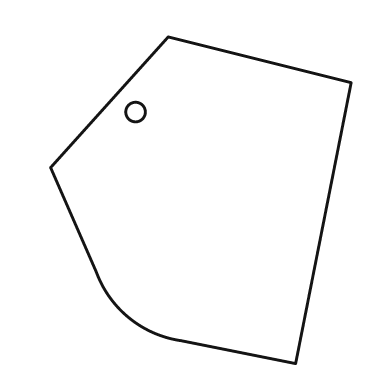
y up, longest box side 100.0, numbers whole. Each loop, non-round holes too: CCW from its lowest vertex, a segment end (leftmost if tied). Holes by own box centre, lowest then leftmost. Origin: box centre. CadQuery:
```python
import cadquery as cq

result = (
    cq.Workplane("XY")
    .moveTo(29.0, -50.0)
    .lineTo(46.0, 36.0)
    .lineTo(-10.0, 50.0)
    .lineTo(-46.0, 10.0)
    .lineTo(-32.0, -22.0)
    .threePointArc((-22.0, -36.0), (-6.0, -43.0))
    .close()
    .moveTo(-20.0, 27.0)
    .circle(3.0)
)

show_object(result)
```